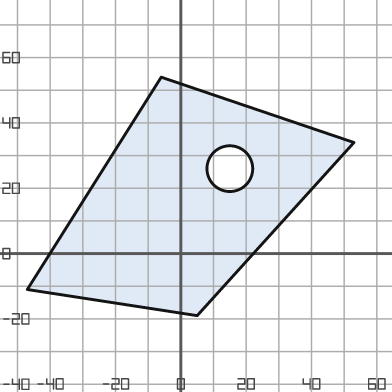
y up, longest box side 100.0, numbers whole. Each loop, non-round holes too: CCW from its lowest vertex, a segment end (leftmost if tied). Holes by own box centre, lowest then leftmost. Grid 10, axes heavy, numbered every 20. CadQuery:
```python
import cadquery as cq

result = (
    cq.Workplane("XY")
    .moveTo(5.0, -19.0)
    .lineTo(53.0, 34.0)
    .lineTo(-6.0, 54.0)
    .lineTo(-47.0, -11.0)
    .close()
    .moveTo(15.0, 26.0)
    .circle(7.0)
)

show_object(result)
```